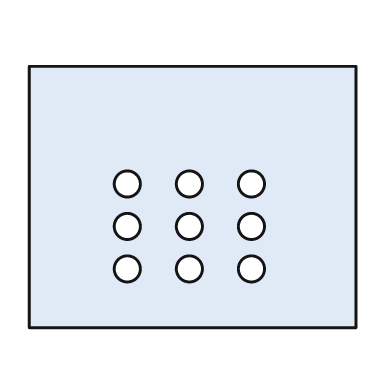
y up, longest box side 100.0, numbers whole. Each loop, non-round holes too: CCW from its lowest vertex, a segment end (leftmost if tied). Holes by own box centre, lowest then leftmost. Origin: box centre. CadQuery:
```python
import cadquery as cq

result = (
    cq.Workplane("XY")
    .moveTo(-50.0, -40.0)
    .lineTo(50.0, -40.0)
    .lineTo(50.0, 40.0)
    .lineTo(-50.0, 40.0)
    .close()
    .moveTo(-20.0, -22.0)
    .circle(4.0)
    .moveTo(-1.0, -22.0)
    .circle(4.0)
    .moveTo(18.0, -22.0)
    .circle(4.0)
    .moveTo(-20.0, -9.0)
    .circle(4.0)
    .moveTo(-1.0, -9.0)
    .circle(4.0)
    .moveTo(18.0, -9.0)
    .circle(4.0)
    .moveTo(-20.0, 4.0)
    .circle(4.0)
    .moveTo(-1.0, 4.0)
    .circle(4.0)
    .moveTo(18.0, 4.0)
    .circle(4.0)
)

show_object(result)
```